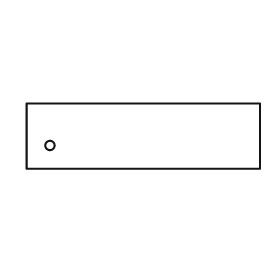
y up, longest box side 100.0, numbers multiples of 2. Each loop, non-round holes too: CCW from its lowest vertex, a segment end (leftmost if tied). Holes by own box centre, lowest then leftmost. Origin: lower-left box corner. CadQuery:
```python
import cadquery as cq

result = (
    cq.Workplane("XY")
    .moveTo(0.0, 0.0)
    .lineTo(100.0, 0.0)
    .lineTo(100.0, 28.0)
    .lineTo(0.0, 28.0)
    .close()
    .moveTo(10.0, 10.0)
    .circle(2.0)
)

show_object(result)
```